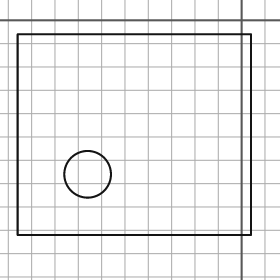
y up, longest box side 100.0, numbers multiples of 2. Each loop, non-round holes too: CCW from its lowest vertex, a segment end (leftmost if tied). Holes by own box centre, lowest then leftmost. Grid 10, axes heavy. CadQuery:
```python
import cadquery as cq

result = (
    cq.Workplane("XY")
    .moveTo(-96.0, -92.0)
    .lineTo(4.0, -92.0)
    .lineTo(4.0, -6.0)
    .lineTo(-96.0, -6.0)
    .close()
    .moveTo(-66.0, -66.0)
    .circle(10.0)
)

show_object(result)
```